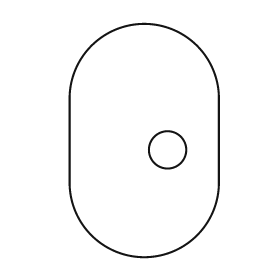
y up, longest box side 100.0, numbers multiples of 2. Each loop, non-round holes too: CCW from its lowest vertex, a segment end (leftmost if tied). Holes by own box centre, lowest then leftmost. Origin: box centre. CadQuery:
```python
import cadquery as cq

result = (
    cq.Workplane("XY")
    .moveTo(-32.0, -18.0)
    .threePointArc((0.0, -50.0), (32.0, -18.0))
    .lineTo(32.0, 18.0)
    .threePointArc((0.0, 50.0), (-32.0, 18.0))
    .close()
    .moveTo(10.0, -4.0)
    .circle(8.0)
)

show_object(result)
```